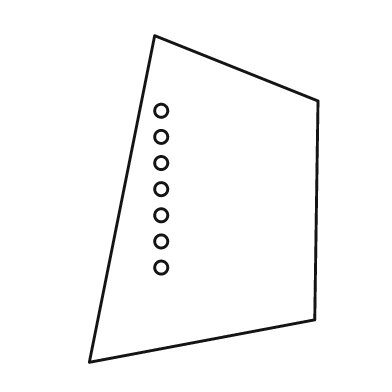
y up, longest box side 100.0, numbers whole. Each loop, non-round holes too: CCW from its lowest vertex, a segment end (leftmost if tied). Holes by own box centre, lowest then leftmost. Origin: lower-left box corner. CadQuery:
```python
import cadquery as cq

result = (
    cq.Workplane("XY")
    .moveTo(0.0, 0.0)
    .lineTo(69.0, 13.0)
    .lineTo(70.0, 80.0)
    .lineTo(20.0, 100.0)
    .close()
    .moveTo(22.0, 29.0)
    .circle(2.0)
    .moveTo(22.0, 37.0)
    .circle(2.0)
    .moveTo(22.0, 45.0)
    .circle(2.0)
    .moveTo(22.0, 53.0)
    .circle(2.0)
    .moveTo(22.0, 61.0)
    .circle(2.0)
    .moveTo(22.0, 69.0)
    .circle(2.0)
    .moveTo(22.0, 77.0)
    .circle(2.0)
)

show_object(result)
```